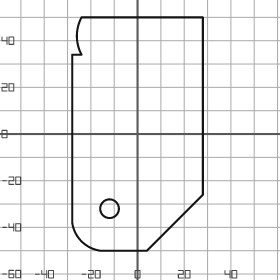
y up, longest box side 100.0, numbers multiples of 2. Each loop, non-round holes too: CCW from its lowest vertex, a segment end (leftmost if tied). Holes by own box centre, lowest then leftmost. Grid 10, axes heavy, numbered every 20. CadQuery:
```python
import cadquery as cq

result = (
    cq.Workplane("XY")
    .moveTo(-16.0, -50.0)
    .lineTo(4.0, -50.0)
    .lineTo(28.0, -26.0)
    .lineTo(28.0, 50.0)
    .lineTo(-24.0, 50.0)
    .threePointArc((-26.0, 42.0), (-24.0, 34.0))
    .lineTo(-28.0, 34.0)
    .lineTo(-28.0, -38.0)
    .threePointArc((-24.0, -46.0), (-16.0, -50.0))
    .close()
    .moveTo(-12.0, -32.0)
    .circle(4.0)
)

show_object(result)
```